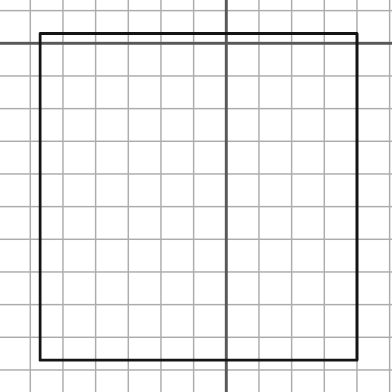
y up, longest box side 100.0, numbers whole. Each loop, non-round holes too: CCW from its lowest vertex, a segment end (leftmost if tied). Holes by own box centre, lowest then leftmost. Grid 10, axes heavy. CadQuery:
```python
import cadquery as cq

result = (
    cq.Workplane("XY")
    .moveTo(-57.0, -97.0)
    .lineTo(40.0, -97.0)
    .lineTo(40.0, 3.0)
    .lineTo(-57.0, 3.0)
    .close()
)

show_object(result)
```